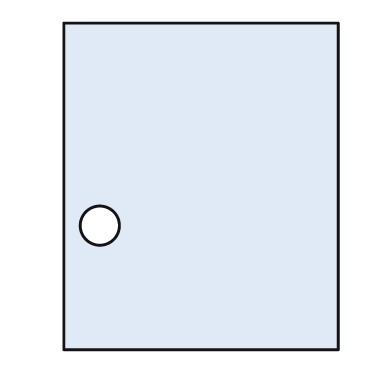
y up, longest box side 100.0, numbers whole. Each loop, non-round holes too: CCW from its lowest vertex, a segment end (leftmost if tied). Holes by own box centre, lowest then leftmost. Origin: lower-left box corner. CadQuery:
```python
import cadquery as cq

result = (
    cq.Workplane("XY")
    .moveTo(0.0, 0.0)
    .lineTo(84.0, 0.0)
    .lineTo(84.0, 100.0)
    .lineTo(0.0, 100.0)
    .close()
    .moveTo(11.0, 38.0)
    .circle(6.0)
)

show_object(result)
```